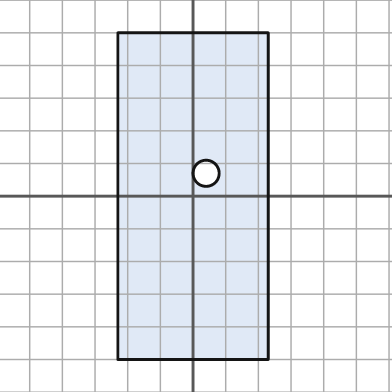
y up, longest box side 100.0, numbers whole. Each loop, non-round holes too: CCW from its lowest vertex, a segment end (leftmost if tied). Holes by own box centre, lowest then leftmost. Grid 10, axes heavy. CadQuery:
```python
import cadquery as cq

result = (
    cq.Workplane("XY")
    .moveTo(-23.0, -50.0)
    .lineTo(23.0, -50.0)
    .lineTo(23.0, 50.0)
    .lineTo(-23.0, 50.0)
    .close()
    .moveTo(4.0, 7.0)
    .circle(4.0)
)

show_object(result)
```